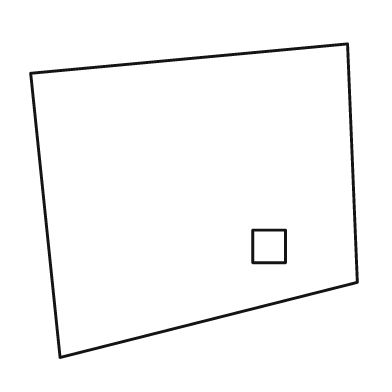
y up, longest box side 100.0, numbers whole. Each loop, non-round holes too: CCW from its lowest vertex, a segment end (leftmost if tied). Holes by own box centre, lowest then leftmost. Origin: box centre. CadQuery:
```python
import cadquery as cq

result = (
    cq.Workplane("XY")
    .moveTo(-41.0, -48.0)
    .lineTo(50.0, -25.0)
    .lineTo(47.0, 48.0)
    .lineTo(-50.0, 39.0)
    .close()
    .moveTo(18.0, -19.0)
    .lineTo(28.0, -19.0)
    .lineTo(28.0, -9.0)
    .lineTo(18.0, -9.0)
    .close()
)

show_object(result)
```